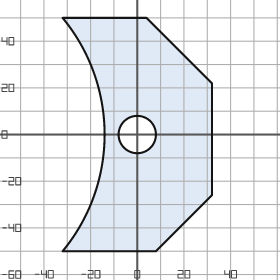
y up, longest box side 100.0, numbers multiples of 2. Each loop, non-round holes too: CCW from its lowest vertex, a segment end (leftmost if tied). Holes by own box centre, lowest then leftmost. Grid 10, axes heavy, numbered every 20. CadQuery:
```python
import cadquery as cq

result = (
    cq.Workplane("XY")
    .moveTo(-32.0, -50.0)
    .lineTo(8.0, -50.0)
    .lineTo(32.0, -26.0)
    .lineTo(32.0, 22.0)
    .lineTo(4.0, 50.0)
    .lineTo(-32.0, 50.0)
    .threePointArc((-14.0, 0.0), (-32.0, -50.0))
    .close()
    .moveTo(0.0, 0.0)
    .circle(8.0)
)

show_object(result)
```